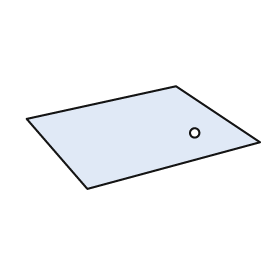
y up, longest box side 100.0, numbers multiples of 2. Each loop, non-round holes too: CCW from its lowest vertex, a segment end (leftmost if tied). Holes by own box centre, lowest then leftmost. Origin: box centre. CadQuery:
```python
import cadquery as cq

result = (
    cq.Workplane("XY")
    .moveTo(-24.0, -22.0)
    .lineTo(50.0, -2.0)
    .lineTo(14.0, 22.0)
    .lineTo(-50.0, 8.0)
    .close()
    .moveTo(22.0, 2.0)
    .circle(2.0)
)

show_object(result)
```